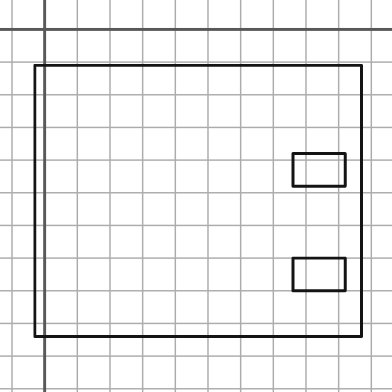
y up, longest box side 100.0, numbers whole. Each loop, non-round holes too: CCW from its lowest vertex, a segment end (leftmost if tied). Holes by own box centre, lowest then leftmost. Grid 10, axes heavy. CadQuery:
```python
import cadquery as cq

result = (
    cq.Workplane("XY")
    .moveTo(-3.0, -94.0)
    .lineTo(97.0, -94.0)
    .lineTo(97.0, -11.0)
    .lineTo(-3.0, -11.0)
    .close()
    .moveTo(76.0, -80.0)
    .lineTo(92.0, -80.0)
    .lineTo(92.0, -70.0)
    .lineTo(76.0, -70.0)
    .close()
    .moveTo(76.0, -48.0)
    .lineTo(92.0, -48.0)
    .lineTo(92.0, -38.0)
    .lineTo(76.0, -38.0)
    .close()
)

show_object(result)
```